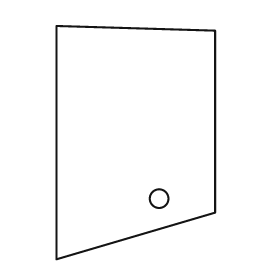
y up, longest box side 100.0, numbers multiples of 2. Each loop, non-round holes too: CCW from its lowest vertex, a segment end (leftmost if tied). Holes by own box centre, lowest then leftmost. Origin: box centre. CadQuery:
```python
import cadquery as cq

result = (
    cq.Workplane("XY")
    .moveTo(-34.0, -50.0)
    .lineTo(34.0, -30.0)
    .lineTo(34.0, 48.0)
    .lineTo(-34.0, 50.0)
    .close()
    .moveTo(10.0, -24.0)
    .circle(4.0)
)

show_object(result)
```